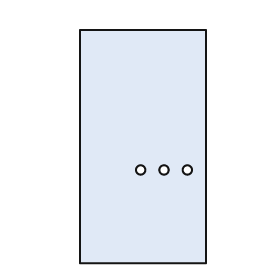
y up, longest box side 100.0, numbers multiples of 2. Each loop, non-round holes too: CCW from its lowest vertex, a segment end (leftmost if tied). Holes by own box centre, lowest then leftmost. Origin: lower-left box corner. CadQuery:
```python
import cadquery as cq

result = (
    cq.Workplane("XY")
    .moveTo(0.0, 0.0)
    .lineTo(54.0, 0.0)
    .lineTo(54.0, 100.0)
    .lineTo(0.0, 100.0)
    .close()
    .moveTo(26.0, 40.0)
    .circle(2.0)
    .moveTo(36.0, 40.0)
    .circle(2.0)
    .moveTo(46.0, 40.0)
    .circle(2.0)
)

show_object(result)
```